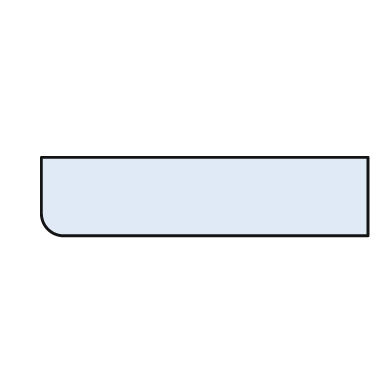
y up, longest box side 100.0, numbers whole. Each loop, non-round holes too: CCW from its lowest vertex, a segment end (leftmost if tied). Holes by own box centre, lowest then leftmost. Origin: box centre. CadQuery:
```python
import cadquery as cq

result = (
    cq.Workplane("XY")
    .moveTo(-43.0, -12.0)
    .lineTo(50.0, -12.0)
    .lineTo(50.0, 12.0)
    .lineTo(-50.0, 12.0)
    .lineTo(-50.0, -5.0)
    .threePointArc((-48.0, -10.0), (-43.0, -12.0))
    .close()
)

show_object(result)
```